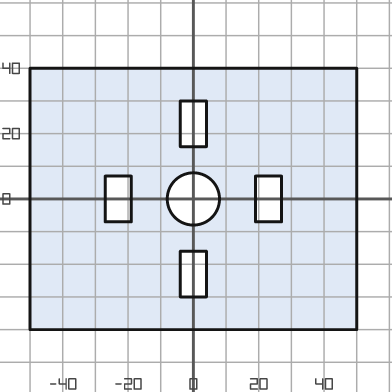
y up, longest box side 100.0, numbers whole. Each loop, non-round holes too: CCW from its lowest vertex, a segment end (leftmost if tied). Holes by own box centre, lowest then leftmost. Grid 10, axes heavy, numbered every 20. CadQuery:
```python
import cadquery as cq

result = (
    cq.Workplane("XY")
    .moveTo(-50.0, -40.0)
    .lineTo(50.0, -40.0)
    .lineTo(50.0, 40.0)
    .lineTo(-50.0, 40.0)
    .close()
    .moveTo(-4.0, -30.0)
    .lineTo(4.0, -30.0)
    .lineTo(4.0, -16.0)
    .lineTo(-4.0, -16.0)
    .close()
    .moveTo(-27.0, -7.0)
    .lineTo(-19.0, -7.0)
    .lineTo(-19.0, 7.0)
    .lineTo(-27.0, 7.0)
    .close()
    .moveTo(0.0, 0.0)
    .circle(8.0)
    .moveTo(19.0, -7.0)
    .lineTo(27.0, -7.0)
    .lineTo(27.0, 7.0)
    .lineTo(19.0, 7.0)
    .close()
    .moveTo(-4.0, 16.0)
    .lineTo(4.0, 16.0)
    .lineTo(4.0, 30.0)
    .lineTo(-4.0, 30.0)
    .close()
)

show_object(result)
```